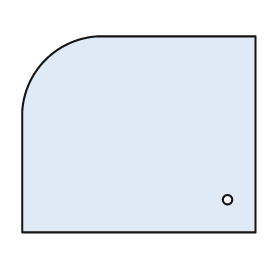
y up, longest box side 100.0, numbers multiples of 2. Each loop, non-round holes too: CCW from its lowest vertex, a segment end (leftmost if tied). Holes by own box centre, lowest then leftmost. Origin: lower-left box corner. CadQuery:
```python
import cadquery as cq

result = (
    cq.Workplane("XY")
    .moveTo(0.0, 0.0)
    .lineTo(100.0, 0.0)
    .lineTo(100.0, 84.0)
    .lineTo(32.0, 84.0)
    .threePointArc((10.0, 74.0), (0.0, 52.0))
    .close()
    .moveTo(88.0, 14.0)
    .circle(2.0)
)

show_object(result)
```